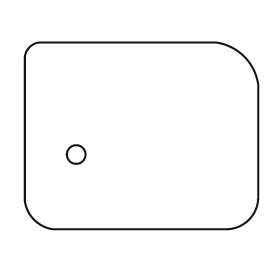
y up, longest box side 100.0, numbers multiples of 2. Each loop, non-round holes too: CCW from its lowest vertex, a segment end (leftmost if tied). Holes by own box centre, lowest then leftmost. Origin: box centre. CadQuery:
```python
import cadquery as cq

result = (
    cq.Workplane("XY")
    .moveTo(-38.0, -40.0)
    .lineTo(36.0, -40.0)
    .threePointArc((46.0, -36.0), (50.0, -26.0))
    .lineTo(50.0, 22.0)
    .threePointArc((44.0, 34.0), (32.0, 40.0))
    .lineTo(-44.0, 40.0)
    .threePointArc((-48.0, 38.0), (-50.0, 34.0))
    .lineTo(-50.0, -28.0)
    .threePointArc((-46.0, -36.0), (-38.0, -40.0))
    .close()
    .moveTo(-28.0, -8.0)
    .circle(4.0)
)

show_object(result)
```